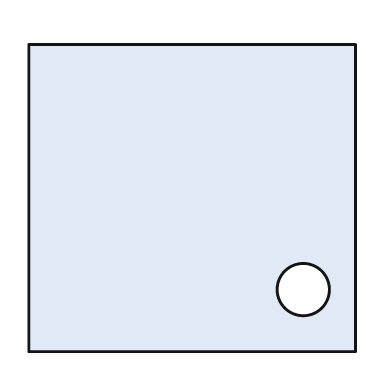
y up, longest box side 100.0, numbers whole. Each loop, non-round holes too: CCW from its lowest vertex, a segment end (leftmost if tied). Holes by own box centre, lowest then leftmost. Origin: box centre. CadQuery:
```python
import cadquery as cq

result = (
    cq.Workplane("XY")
    .moveTo(-50.0, -47.0)
    .lineTo(50.0, -47.0)
    .lineTo(50.0, 47.0)
    .lineTo(-50.0, 47.0)
    .close()
    .moveTo(34.0, -28.0)
    .circle(8.0)
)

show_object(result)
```